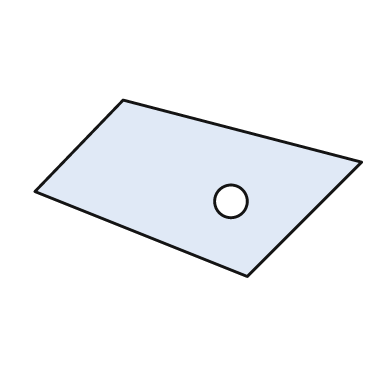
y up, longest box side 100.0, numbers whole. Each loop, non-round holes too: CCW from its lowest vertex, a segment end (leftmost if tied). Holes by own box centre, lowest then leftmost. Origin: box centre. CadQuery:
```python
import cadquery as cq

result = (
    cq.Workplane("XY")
    .moveTo(15.0, -27.0)
    .lineTo(50.0, 8.0)
    .lineTo(-23.0, 27.0)
    .lineTo(-50.0, -1.0)
    .close()
    .moveTo(10.0, -4.0)
    .circle(5.0)
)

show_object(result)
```